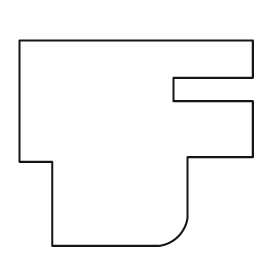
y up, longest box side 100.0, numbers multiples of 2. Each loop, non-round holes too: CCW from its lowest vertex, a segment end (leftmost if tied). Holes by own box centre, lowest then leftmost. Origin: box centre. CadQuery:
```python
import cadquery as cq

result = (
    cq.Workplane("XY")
    .moveTo(-36.0, -44.0)
    .lineTo(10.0, -44.0)
    .threePointArc((18.0, -40.0), (22.0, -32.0))
    .lineTo(22.0, -6.0)
    .lineTo(50.0, -6.0)
    .lineTo(50.0, 18.0)
    .lineTo(16.0, 18.0)
    .lineTo(16.0, 28.0)
    .lineTo(50.0, 28.0)
    .lineTo(50.0, 44.0)
    .lineTo(-50.0, 44.0)
    .lineTo(-50.0, -8.0)
    .lineTo(-36.0, -8.0)
    .close()
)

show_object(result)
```